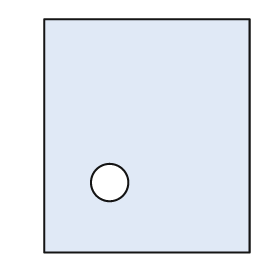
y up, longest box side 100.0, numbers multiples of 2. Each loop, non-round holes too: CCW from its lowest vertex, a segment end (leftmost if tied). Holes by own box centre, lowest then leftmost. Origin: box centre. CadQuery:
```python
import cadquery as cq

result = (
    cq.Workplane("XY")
    .moveTo(-44.0, -50.0)
    .lineTo(44.0, -50.0)
    .lineTo(44.0, 50.0)
    .lineTo(-44.0, 50.0)
    .close()
    .moveTo(-16.0, -20.0)
    .circle(8.0)
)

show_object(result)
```